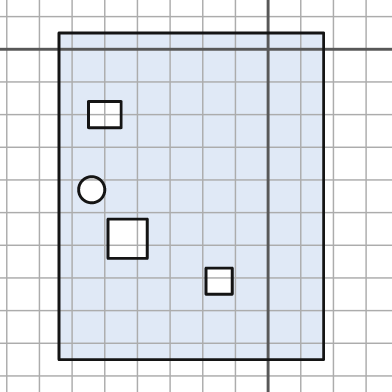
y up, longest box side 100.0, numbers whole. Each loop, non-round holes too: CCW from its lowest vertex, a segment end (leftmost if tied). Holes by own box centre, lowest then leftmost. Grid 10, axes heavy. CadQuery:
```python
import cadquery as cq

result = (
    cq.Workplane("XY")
    .moveTo(-64.0, -95.0)
    .lineTo(17.0, -95.0)
    .lineTo(17.0, 5.0)
    .lineTo(-64.0, 5.0)
    .close()
    .moveTo(-19.0, -75.0)
    .lineTo(-11.0, -75.0)
    .lineTo(-11.0, -67.0)
    .lineTo(-19.0, -67.0)
    .close()
    .moveTo(-49.0, -64.0)
    .lineTo(-37.0, -64.0)
    .lineTo(-37.0, -52.0)
    .lineTo(-49.0, -52.0)
    .close()
    .moveTo(-54.0, -43.0)
    .circle(4.0)
    .moveTo(-55.0, -24.0)
    .lineTo(-45.0, -24.0)
    .lineTo(-45.0, -16.0)
    .lineTo(-55.0, -16.0)
    .close()
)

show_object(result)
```